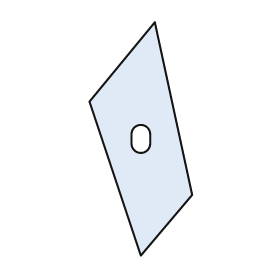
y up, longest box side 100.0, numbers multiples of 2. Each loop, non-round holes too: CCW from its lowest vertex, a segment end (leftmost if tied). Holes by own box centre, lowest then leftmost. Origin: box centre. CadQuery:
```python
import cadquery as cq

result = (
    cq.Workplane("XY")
    .moveTo(0.0, -50.0)
    .lineTo(22.0, -24.0)
    .lineTo(6.0, 50.0)
    .lineTo(-22.0, 16.0)
    .close()
    .moveTo(-4.0, -2.0)
    .threePointArc((0.0, -6.0), (4.0, -2.0))
    .lineTo(4.0, 2.0)
    .threePointArc((0.0, 6.0), (-4.0, 2.0))
    .close()
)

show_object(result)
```